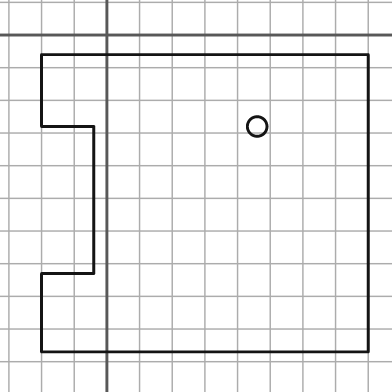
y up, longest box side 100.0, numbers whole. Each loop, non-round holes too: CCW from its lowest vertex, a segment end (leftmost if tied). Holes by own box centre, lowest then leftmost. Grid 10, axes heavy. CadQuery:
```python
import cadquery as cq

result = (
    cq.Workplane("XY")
    .moveTo(-20.0, -97.0)
    .lineTo(80.0, -97.0)
    .lineTo(80.0, -6.0)
    .lineTo(-20.0, -6.0)
    .lineTo(-20.0, -28.0)
    .lineTo(-4.0, -28.0)
    .lineTo(-4.0, -73.0)
    .lineTo(-20.0, -73.0)
    .close()
    .moveTo(46.0, -28.0)
    .circle(3.0)
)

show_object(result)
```